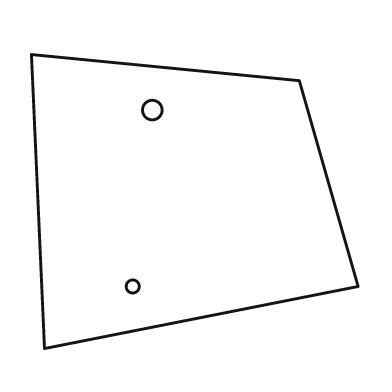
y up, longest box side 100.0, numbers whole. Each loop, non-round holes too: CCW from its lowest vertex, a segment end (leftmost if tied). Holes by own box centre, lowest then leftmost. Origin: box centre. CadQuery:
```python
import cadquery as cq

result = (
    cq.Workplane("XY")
    .moveTo(-46.0, -45.0)
    .lineTo(50.0, -26.0)
    .lineTo(32.0, 37.0)
    .lineTo(-50.0, 45.0)
    .close()
    .moveTo(-19.0, -26.0)
    .circle(2.0)
    .moveTo(-13.0, 28.0)
    .circle(3.0)
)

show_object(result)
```